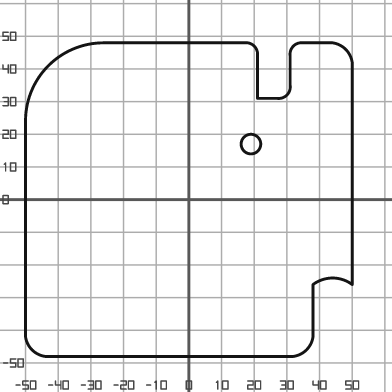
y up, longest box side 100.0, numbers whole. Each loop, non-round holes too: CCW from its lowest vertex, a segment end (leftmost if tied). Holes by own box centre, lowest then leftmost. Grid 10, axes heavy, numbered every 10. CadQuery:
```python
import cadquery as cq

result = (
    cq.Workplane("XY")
    .moveTo(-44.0, -48.0)
    .lineTo(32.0, -48.0)
    .threePointArc((36.0, -46.0), (38.0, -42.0))
    .lineTo(38.0, -26.0)
    .threePointArc((44.0, -24.0), (50.0, -26.0))
    .lineTo(50.0, 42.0)
    .threePointArc((48.0, 46.0), (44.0, 48.0))
    .lineTo(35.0, 48.0)
    .threePointArc((32.0, 47.0), (31.0, 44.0))
    .lineTo(31.0, 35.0)
    .threePointArc((30.0, 32.0), (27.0, 31.0))
    .lineTo(21.0, 31.0)
    .lineTo(21.0, 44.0)
    .threePointArc((20.0, 47.0), (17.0, 48.0))
    .lineTo(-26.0, 48.0)
    .threePointArc((-43.0, 41.0), (-50.0, 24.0))
    .lineTo(-50.0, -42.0)
    .threePointArc((-48.0, -46.0), (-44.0, -48.0))
    .close()
    .moveTo(19.0, 17.0)
    .circle(3.0)
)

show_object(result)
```